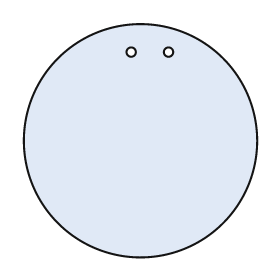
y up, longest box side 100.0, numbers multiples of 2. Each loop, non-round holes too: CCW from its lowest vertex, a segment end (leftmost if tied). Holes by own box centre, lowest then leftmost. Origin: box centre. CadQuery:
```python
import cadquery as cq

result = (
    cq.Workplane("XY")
    .moveTo(0.0, 0.0)
    .circle(50.0)
    .moveTo(-4.0, 38.0)
    .circle(2.0)
    .moveTo(12.0, 38.0)
    .circle(2.0)
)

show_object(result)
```